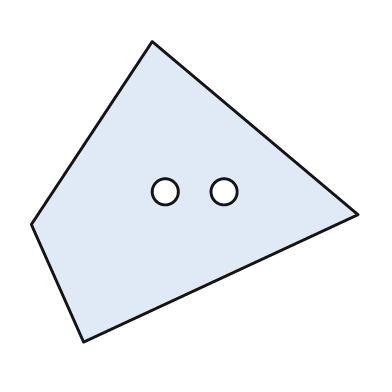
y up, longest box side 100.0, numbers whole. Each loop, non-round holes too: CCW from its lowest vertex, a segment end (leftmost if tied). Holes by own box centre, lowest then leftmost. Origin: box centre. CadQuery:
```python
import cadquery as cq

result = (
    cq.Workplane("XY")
    .moveTo(-34.0, -46.0)
    .lineTo(50.0, -7.0)
    .lineTo(-13.0, 46.0)
    .lineTo(-50.0, -10.0)
    .close()
    .moveTo(-9.0, 0.0)
    .circle(4.0)
    .moveTo(9.0, 0.0)
    .circle(4.0)
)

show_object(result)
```